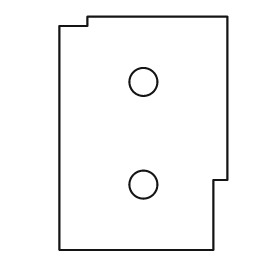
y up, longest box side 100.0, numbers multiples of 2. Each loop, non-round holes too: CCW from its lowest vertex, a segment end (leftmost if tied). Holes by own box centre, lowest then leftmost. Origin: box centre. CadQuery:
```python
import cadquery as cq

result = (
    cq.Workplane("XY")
    .moveTo(-36.0, -50.0)
    .lineTo(30.0, -50.0)
    .lineTo(30.0, -20.0)
    .lineTo(36.0, -20.0)
    .lineTo(36.0, 50.0)
    .lineTo(-24.0, 50.0)
    .lineTo(-24.0, 46.0)
    .lineTo(-36.0, 46.0)
    .close()
    .moveTo(0.0, -22.0)
    .circle(6.0)
    .moveTo(0.0, 22.0)
    .circle(6.0)
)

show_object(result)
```